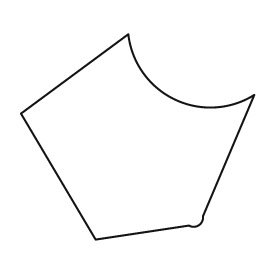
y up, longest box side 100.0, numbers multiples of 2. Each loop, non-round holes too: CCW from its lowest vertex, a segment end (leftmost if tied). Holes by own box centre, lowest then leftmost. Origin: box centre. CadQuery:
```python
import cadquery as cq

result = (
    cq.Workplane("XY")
    .moveTo(-18.0, -44.0)
    .lineTo(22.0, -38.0)
    .threePointArc((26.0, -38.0), (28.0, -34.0))
    .lineTo(50.0, 18.0)
    .threePointArc((16.0, 16.0), (-4.0, 44.0))
    .lineTo(-50.0, 10.0)
    .close()
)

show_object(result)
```